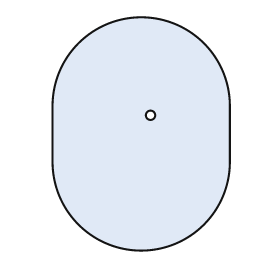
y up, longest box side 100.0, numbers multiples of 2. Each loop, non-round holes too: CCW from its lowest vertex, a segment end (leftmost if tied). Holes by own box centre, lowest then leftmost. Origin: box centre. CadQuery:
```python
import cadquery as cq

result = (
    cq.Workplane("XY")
    .moveTo(-38.0, -12.0)
    .threePointArc((0.0, -50.0), (38.0, -12.0))
    .lineTo(38.0, 12.0)
    .threePointArc((0.0, 50.0), (-38.0, 12.0))
    .close()
    .moveTo(4.0, 8.0)
    .circle(2.0)
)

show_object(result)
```